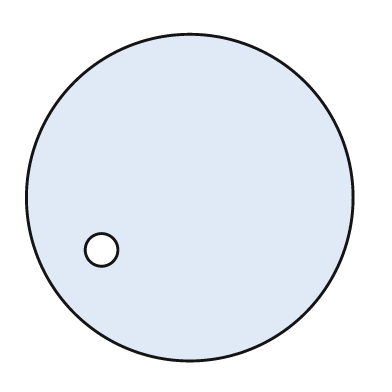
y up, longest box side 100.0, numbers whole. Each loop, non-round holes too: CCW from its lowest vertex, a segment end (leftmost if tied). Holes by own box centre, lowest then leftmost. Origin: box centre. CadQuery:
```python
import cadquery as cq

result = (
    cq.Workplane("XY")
    .moveTo(0.0, 0.0)
    .circle(50.0)
    .moveTo(-27.0, -16.0)
    .circle(5.0)
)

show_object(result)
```